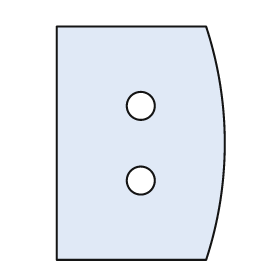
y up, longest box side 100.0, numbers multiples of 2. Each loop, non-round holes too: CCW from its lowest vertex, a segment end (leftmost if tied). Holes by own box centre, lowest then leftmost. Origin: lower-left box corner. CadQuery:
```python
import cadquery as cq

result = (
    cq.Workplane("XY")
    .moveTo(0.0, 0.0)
    .lineTo(64.0, 0.0)
    .threePointArc((72.0, 50.0), (64.0, 100.0))
    .lineTo(0.0, 100.0)
    .close()
    .moveTo(36.0, 34.0)
    .circle(6.0)
    .moveTo(36.0, 66.0)
    .circle(6.0)
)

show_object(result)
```